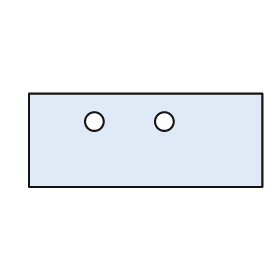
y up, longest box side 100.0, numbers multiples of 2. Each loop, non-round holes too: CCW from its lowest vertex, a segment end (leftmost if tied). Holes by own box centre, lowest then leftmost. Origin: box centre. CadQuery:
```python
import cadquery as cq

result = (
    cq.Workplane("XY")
    .moveTo(-50.0, -20.0)
    .lineTo(50.0, -20.0)
    .lineTo(50.0, 20.0)
    .lineTo(-50.0, 20.0)
    .close()
    .moveTo(-22.0, 8.0)
    .circle(4.0)
    .moveTo(8.0, 8.0)
    .circle(4.0)
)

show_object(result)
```